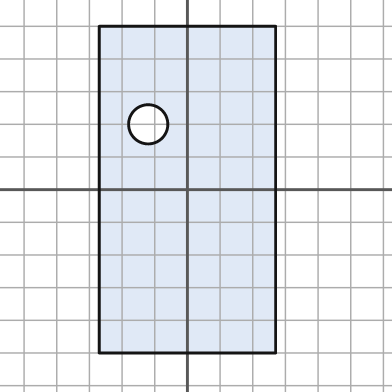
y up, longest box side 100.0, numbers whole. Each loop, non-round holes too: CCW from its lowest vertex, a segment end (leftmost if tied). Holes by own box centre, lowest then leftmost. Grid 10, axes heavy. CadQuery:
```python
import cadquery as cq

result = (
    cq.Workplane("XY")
    .moveTo(-27.0, -50.0)
    .lineTo(27.0, -50.0)
    .lineTo(27.0, 50.0)
    .lineTo(-27.0, 50.0)
    .close()
    .moveTo(-12.0, 20.0)
    .circle(6.0)
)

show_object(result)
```